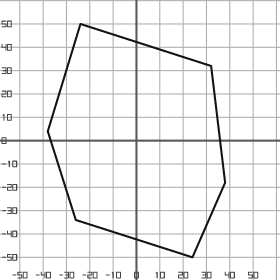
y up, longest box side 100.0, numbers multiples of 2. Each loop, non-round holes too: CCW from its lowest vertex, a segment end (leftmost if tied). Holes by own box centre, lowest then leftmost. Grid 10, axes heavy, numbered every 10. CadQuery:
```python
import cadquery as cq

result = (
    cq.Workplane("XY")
    .moveTo(24.0, -50.0)
    .lineTo(38.0, -18.0)
    .lineTo(32.0, 32.0)
    .lineTo(-24.0, 50.0)
    .lineTo(-38.0, 4.0)
    .lineTo(-26.0, -34.0)
    .close()
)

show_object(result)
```